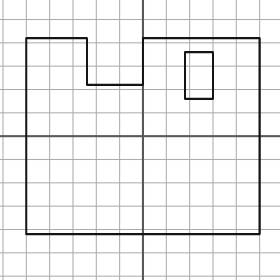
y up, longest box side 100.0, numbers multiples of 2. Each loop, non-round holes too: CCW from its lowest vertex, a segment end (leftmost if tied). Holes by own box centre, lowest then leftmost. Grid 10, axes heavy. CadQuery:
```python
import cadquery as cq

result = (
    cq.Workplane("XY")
    .moveTo(-50.0, -42.0)
    .lineTo(50.0, -42.0)
    .lineTo(50.0, 42.0)
    .lineTo(0.0, 42.0)
    .lineTo(0.0, 22.0)
    .lineTo(-24.0, 22.0)
    .lineTo(-24.0, 42.0)
    .lineTo(-50.0, 42.0)
    .close()
    .moveTo(18.0, 16.0)
    .lineTo(30.0, 16.0)
    .lineTo(30.0, 36.0)
    .lineTo(18.0, 36.0)
    .close()
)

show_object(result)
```